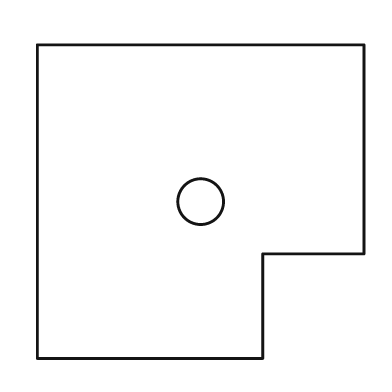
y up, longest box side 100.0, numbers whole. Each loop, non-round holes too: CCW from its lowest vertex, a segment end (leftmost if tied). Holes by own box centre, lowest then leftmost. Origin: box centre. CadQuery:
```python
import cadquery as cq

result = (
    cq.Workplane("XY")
    .moveTo(-50.0, -48.0)
    .lineTo(19.0, -48.0)
    .lineTo(19.0, -16.0)
    .lineTo(50.0, -16.0)
    .lineTo(50.0, 48.0)
    .lineTo(-50.0, 48.0)
    .close()
    .moveTo(0.0, 0.0)
    .circle(7.0)
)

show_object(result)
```